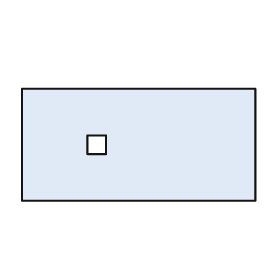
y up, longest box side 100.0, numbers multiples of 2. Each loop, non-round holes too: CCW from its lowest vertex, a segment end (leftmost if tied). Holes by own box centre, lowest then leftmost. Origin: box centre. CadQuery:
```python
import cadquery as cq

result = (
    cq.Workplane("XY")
    .moveTo(-50.0, -24.0)
    .lineTo(50.0, -24.0)
    .lineTo(50.0, 24.0)
    .lineTo(-50.0, 24.0)
    .close()
    .moveTo(-22.0, -4.0)
    .lineTo(-14.0, -4.0)
    .lineTo(-14.0, 4.0)
    .lineTo(-22.0, 4.0)
    .close()
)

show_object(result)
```